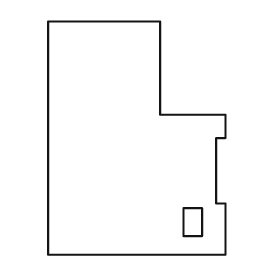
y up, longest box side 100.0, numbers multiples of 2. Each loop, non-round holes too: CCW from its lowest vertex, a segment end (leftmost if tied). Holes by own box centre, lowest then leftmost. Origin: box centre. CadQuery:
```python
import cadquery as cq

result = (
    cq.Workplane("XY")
    .moveTo(-38.0, -50.0)
    .lineTo(38.0, -50.0)
    .lineTo(38.0, -28.0)
    .lineTo(34.0, -28.0)
    .lineTo(34.0, 0.0)
    .lineTo(38.0, 0.0)
    .lineTo(38.0, 10.0)
    .lineTo(10.0, 10.0)
    .lineTo(10.0, 50.0)
    .lineTo(-38.0, 50.0)
    .close()
    .moveTo(20.0, -42.0)
    .lineTo(28.0, -42.0)
    .lineTo(28.0, -30.0)
    .lineTo(20.0, -30.0)
    .close()
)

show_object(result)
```